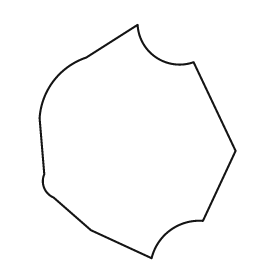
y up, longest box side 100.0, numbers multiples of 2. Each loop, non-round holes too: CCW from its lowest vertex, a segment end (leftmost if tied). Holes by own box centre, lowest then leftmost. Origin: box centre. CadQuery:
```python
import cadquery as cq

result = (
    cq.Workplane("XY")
    .moveTo(6.0, -50.0)
    .threePointArc((14.0, -38.0), (28.0, -34.0))
    .lineTo(42.0, -4.0)
    .lineTo(24.0, 34.0)
    .threePointArc((8.0, 36.0), (0.0, 50.0))
    .lineTo(-22.0, 36.0)
    .threePointArc((-36.0, 26.0), (-42.0, 10.0))
    .lineTo(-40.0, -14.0)
    .threePointArc((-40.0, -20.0), (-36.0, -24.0))
    .lineTo(-20.0, -38.0)
    .close()
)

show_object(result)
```